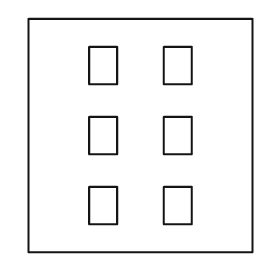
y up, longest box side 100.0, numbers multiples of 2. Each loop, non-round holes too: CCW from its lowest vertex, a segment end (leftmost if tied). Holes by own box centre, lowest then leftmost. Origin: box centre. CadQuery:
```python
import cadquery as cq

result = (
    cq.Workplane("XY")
    .moveTo(-48.0, -50.0)
    .lineTo(48.0, -50.0)
    .lineTo(48.0, 50.0)
    .lineTo(-48.0, 50.0)
    .close()
    .moveTo(-22.0, -38.0)
    .lineTo(-10.0, -38.0)
    .lineTo(-10.0, -22.0)
    .lineTo(-22.0, -22.0)
    .close()
    .moveTo(10.0, -38.0)
    .lineTo(22.0, -38.0)
    .lineTo(22.0, -22.0)
    .lineTo(10.0, -22.0)
    .close()
    .moveTo(-22.0, -8.0)
    .lineTo(-10.0, -8.0)
    .lineTo(-10.0, 8.0)
    .lineTo(-22.0, 8.0)
    .close()
    .moveTo(10.0, -8.0)
    .lineTo(22.0, -8.0)
    .lineTo(22.0, 8.0)
    .lineTo(10.0, 8.0)
    .close()
    .moveTo(-22.0, 22.0)
    .lineTo(-10.0, 22.0)
    .lineTo(-10.0, 38.0)
    .lineTo(-22.0, 38.0)
    .close()
    .moveTo(10.0, 22.0)
    .lineTo(22.0, 22.0)
    .lineTo(22.0, 38.0)
    .lineTo(10.0, 38.0)
    .close()
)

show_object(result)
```